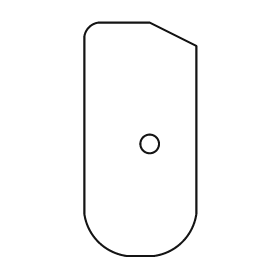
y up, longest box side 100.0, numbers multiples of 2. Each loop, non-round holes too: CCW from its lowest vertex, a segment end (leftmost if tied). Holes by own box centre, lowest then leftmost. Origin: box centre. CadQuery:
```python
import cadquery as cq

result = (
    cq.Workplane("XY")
    .moveTo(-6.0, -50.0)
    .lineTo(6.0, -50.0)
    .threePointArc((18.0, -44.0), (24.0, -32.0))
    .lineTo(24.0, 40.0)
    .lineTo(4.0, 50.0)
    .lineTo(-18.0, 50.0)
    .threePointArc((-22.0, 48.0), (-24.0, 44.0))
    .lineTo(-24.0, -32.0)
    .threePointArc((-18.0, -44.0), (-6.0, -50.0))
    .close()
    .moveTo(4.0, -2.0)
    .circle(4.0)
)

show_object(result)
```